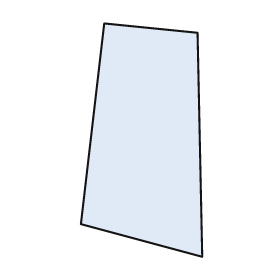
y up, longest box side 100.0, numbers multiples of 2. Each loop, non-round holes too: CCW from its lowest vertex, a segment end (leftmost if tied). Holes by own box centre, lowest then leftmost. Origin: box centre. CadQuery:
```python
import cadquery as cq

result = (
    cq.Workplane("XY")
    .moveTo(26.0, -50.0)
    .lineTo(24.0, 46.0)
    .lineTo(-16.0, 50.0)
    .lineTo(-26.0, -36.0)
    .close()
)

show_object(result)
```